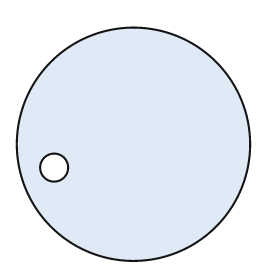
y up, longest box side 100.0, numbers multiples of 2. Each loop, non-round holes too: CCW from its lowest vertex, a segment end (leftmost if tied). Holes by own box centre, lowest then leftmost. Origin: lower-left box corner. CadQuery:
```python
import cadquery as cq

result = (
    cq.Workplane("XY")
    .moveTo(50.0, 50.0)
    .circle(50.0)
    .moveTo(16.0, 40.0)
    .circle(6.0)
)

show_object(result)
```